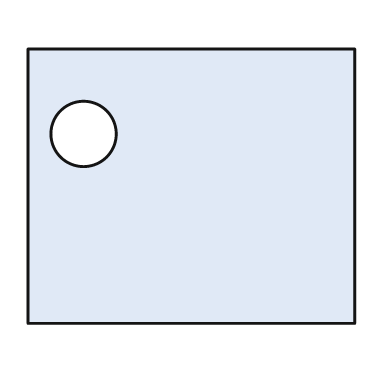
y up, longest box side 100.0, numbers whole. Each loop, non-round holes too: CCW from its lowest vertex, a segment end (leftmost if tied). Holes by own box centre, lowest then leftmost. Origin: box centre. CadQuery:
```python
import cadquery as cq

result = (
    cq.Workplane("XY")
    .moveTo(-50.0, -42.0)
    .lineTo(50.0, -42.0)
    .lineTo(50.0, 42.0)
    .lineTo(-50.0, 42.0)
    .close()
    .moveTo(-33.0, 16.0)
    .circle(10.0)
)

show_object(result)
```